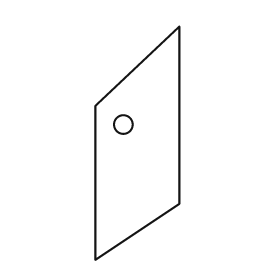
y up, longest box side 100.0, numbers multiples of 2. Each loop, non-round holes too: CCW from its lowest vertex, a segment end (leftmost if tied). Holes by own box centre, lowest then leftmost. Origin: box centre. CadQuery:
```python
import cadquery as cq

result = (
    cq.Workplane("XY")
    .moveTo(-18.0, -50.0)
    .lineTo(18.0, -26.0)
    .lineTo(18.0, 50.0)
    .lineTo(-18.0, 16.0)
    .close()
    .moveTo(-6.0, 8.0)
    .circle(4.0)
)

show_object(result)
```